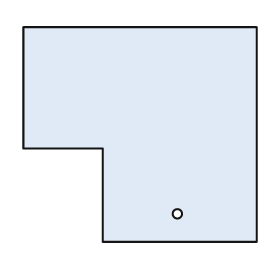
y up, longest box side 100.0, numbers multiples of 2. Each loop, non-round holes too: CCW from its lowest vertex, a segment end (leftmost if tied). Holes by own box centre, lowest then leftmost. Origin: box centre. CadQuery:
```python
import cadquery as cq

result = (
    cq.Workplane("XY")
    .moveTo(-16.0, -46.0)
    .lineTo(50.0, -46.0)
    .lineTo(50.0, 46.0)
    .lineTo(-50.0, 46.0)
    .lineTo(-50.0, -6.0)
    .lineTo(-16.0, -6.0)
    .close()
    .moveTo(16.0, -34.0)
    .circle(2.0)
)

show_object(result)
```